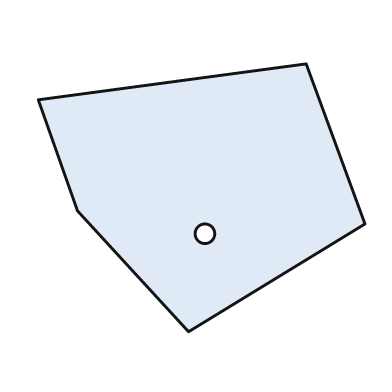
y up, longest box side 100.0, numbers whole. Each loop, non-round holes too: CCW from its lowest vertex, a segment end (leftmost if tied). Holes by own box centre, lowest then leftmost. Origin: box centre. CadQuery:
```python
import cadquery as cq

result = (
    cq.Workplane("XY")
    .moveTo(-4.0, -41.0)
    .lineTo(50.0, -8.0)
    .lineTo(32.0, 41.0)
    .lineTo(-50.0, 30.0)
    .lineTo(-38.0, -4.0)
    .close()
    .moveTo(1.0, -11.0)
    .circle(3.0)
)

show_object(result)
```